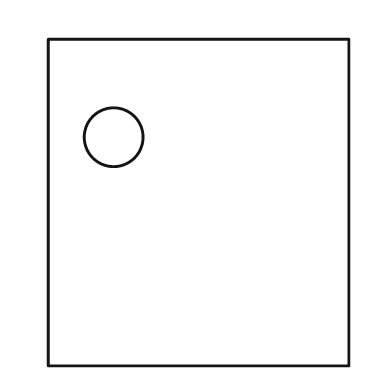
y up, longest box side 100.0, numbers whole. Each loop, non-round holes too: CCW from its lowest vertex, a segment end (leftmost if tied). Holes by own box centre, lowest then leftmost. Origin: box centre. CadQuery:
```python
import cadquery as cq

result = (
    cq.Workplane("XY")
    .moveTo(-46.0, -50.0)
    .lineTo(46.0, -50.0)
    .lineTo(46.0, 50.0)
    .lineTo(-46.0, 50.0)
    .close()
    .moveTo(-26.0, 20.0)
    .circle(9.0)
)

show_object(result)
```